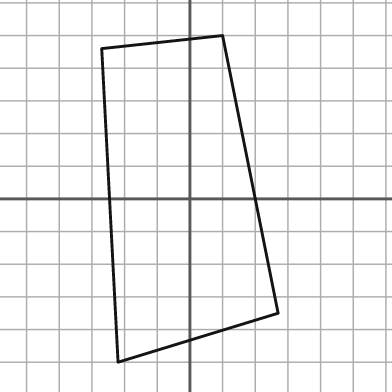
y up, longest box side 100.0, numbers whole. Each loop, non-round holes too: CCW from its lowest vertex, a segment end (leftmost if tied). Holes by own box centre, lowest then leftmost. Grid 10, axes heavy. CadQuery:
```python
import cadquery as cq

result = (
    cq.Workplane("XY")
    .moveTo(-22.0, -50.0)
    .lineTo(27.0, -35.0)
    .lineTo(10.0, 50.0)
    .lineTo(-27.0, 46.0)
    .close()
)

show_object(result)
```